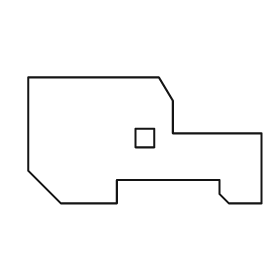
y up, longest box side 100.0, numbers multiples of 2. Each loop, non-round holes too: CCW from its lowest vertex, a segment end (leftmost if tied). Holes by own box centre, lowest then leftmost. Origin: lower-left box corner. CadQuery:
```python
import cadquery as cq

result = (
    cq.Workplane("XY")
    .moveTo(14.0, 0.0)
    .lineTo(38.0, 0.0)
    .lineTo(38.0, 10.0)
    .lineTo(82.0, 10.0)
    .lineTo(82.0, 4.0)
    .lineTo(86.0, 0.0)
    .lineTo(100.0, 0.0)
    .lineTo(100.0, 30.0)
    .lineTo(62.0, 30.0)
    .lineTo(62.0, 44.0)
    .lineTo(56.0, 54.0)
    .lineTo(0.0, 54.0)
    .lineTo(0.0, 14.0)
    .close()
    .moveTo(46.0, 24.0)
    .lineTo(54.0, 24.0)
    .lineTo(54.0, 32.0)
    .lineTo(46.0, 32.0)
    .close()
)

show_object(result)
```